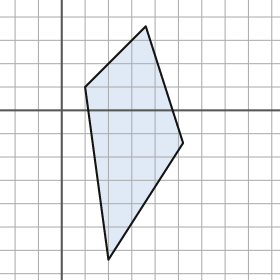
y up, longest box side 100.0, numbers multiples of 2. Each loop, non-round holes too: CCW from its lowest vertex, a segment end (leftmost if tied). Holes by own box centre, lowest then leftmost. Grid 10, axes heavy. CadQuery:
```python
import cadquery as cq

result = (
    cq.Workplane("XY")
    .moveTo(20.0, -64.0)
    .lineTo(52.0, -14.0)
    .lineTo(36.0, 36.0)
    .lineTo(10.0, 10.0)
    .close()
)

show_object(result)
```